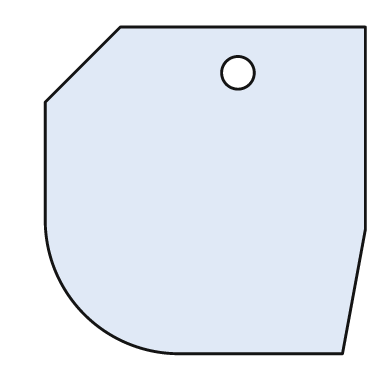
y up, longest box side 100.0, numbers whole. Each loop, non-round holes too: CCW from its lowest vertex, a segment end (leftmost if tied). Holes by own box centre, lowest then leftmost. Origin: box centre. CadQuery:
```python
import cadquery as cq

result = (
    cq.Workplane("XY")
    .moveTo(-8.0, -50.0)
    .lineTo(42.0, -50.0)
    .lineTo(49.0, -12.0)
    .lineTo(49.0, 50.0)
    .lineTo(-26.0, 50.0)
    .lineTo(-49.0, 27.0)
    .lineTo(-49.0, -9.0)
    .threePointArc((-37.0, -38.0), (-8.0, -50.0))
    .close()
    .moveTo(10.0, 36.0)
    .circle(5.0)
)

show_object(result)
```